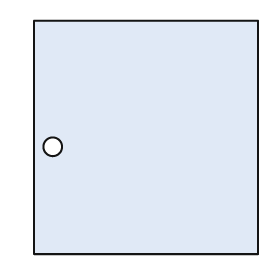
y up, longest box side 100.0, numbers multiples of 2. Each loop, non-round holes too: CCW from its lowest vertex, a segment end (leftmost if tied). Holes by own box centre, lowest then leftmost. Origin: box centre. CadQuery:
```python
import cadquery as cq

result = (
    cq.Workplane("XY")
    .moveTo(-48.0, -50.0)
    .lineTo(48.0, -50.0)
    .lineTo(48.0, 50.0)
    .lineTo(-48.0, 50.0)
    .close()
    .moveTo(-40.0, -4.0)
    .circle(4.0)
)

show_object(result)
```